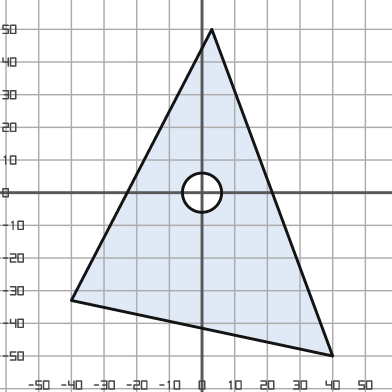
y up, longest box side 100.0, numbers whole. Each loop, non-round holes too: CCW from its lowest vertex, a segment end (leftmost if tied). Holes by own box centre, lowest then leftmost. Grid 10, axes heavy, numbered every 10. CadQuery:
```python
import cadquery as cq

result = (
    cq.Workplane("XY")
    .moveTo(40.0, -50.0)
    .lineTo(3.0, 50.0)
    .lineTo(-40.0, -33.0)
    .close()
    .moveTo(0.0, 0.0)
    .circle(6.0)
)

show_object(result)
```